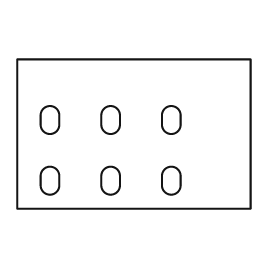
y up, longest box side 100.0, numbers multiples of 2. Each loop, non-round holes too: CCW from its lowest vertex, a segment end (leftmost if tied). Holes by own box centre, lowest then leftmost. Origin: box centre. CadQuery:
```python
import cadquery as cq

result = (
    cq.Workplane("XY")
    .moveTo(-50.0, -32.0)
    .lineTo(50.0, -32.0)
    .lineTo(50.0, 32.0)
    .lineTo(-50.0, 32.0)
    .close()
    .moveTo(-40.0, -22.0)
    .threePointArc((-36.0, -26.0), (-32.0, -22.0))
    .lineTo(-32.0, -18.0)
    .threePointArc((-36.0, -14.0), (-40.0, -18.0))
    .close()
    .moveTo(-14.0, -22.0)
    .threePointArc((-10.0, -26.0), (-6.0, -22.0))
    .lineTo(-6.0, -18.0)
    .threePointArc((-10.0, -14.0), (-14.0, -18.0))
    .close()
    .moveTo(12.0, -22.0)
    .threePointArc((16.0, -26.0), (20.0, -22.0))
    .lineTo(20.0, -18.0)
    .threePointArc((16.0, -14.0), (12.0, -18.0))
    .close()
    .moveTo(-40.0, 4.0)
    .threePointArc((-36.0, 0.0), (-32.0, 4.0))
    .lineTo(-32.0, 8.0)
    .threePointArc((-36.0, 12.0), (-40.0, 8.0))
    .close()
    .moveTo(-14.0, 4.0)
    .threePointArc((-10.0, 0.0), (-6.0, 4.0))
    .lineTo(-6.0, 8.0)
    .threePointArc((-10.0, 12.0), (-14.0, 8.0))
    .close()
    .moveTo(12.0, 4.0)
    .threePointArc((16.0, 0.0), (20.0, 4.0))
    .lineTo(20.0, 8.0)
    .threePointArc((16.0, 12.0), (12.0, 8.0))
    .close()
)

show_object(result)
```